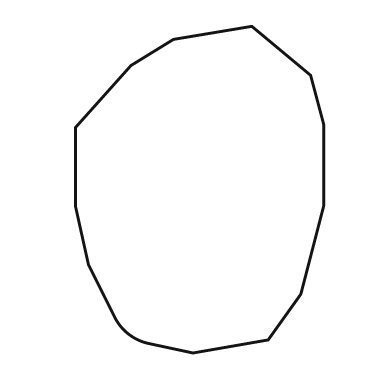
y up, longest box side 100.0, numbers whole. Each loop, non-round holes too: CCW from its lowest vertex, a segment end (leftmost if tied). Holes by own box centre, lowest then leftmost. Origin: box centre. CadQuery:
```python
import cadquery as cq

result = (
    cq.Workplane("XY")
    .moveTo(-2.0, -50.0)
    .lineTo(21.0, -46.0)
    .lineTo(31.0, -32.0)
    .lineTo(38.0, -5.0)
    .lineTo(38.0, 20.0)
    .lineTo(34.0, 35.0)
    .lineTo(16.0, 50.0)
    .lineTo(-8.0, 46.0)
    .lineTo(-21.0, 38.0)
    .lineTo(-38.0, 19.0)
    .lineTo(-38.0, -5.0)
    .lineTo(-34.0, -23.0)
    .lineTo(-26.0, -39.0)
    .threePointArc((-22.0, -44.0), (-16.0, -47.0))
    .close()
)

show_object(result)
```